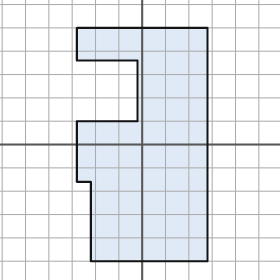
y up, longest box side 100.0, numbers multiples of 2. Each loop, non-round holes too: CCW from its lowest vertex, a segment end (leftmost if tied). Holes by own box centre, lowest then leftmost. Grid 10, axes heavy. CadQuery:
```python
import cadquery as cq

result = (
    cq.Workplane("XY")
    .moveTo(-22.0, -50.0)
    .lineTo(28.0, -50.0)
    .lineTo(28.0, 50.0)
    .lineTo(-28.0, 50.0)
    .lineTo(-28.0, 36.0)
    .lineTo(-2.0, 36.0)
    .lineTo(-2.0, 10.0)
    .lineTo(-28.0, 10.0)
    .lineTo(-28.0, -16.0)
    .lineTo(-22.0, -16.0)
    .close()
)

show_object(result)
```